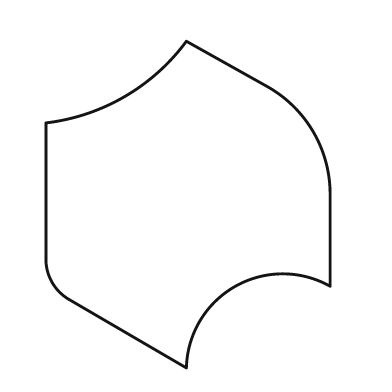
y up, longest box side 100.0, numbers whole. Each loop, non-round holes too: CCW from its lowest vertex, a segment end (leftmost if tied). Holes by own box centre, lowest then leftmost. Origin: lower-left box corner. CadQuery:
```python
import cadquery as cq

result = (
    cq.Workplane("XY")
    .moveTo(43.0, 0.0)
    .threePointArc((58.0, 25.0), (87.0, 25.0))
    .lineTo(87.0, 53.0)
    .threePointArc((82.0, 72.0), (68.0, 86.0))
    .lineTo(43.0, 100.0)
    .threePointArc((24.0, 83.0), (0.0, 75.0))
    .lineTo(0.0, 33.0)
    .threePointArc((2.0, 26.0), (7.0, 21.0))
    .close()
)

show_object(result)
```